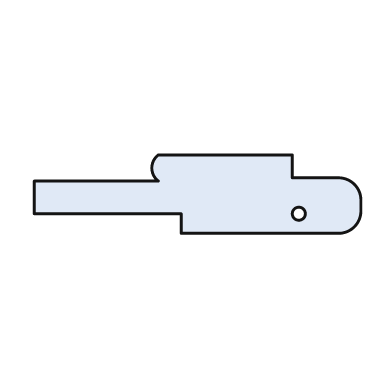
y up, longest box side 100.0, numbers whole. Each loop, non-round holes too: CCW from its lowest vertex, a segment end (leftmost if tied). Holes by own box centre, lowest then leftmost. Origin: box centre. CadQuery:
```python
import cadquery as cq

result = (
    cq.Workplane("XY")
    .moveTo(-5.0, -12.0)
    .lineTo(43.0, -12.0)
    .threePointArc((48.0, -10.0), (50.0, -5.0))
    .lineTo(50.0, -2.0)
    .threePointArc((48.0, 3.0), (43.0, 5.0))
    .lineTo(29.0, 5.0)
    .lineTo(29.0, 12.0)
    .lineTo(-12.0, 12.0)
    .threePointArc((-14.0, 8.0), (-12.0, 4.0))
    .lineTo(-50.0, 4.0)
    .lineTo(-50.0, -6.0)
    .lineTo(-5.0, -6.0)
    .close()
    .moveTo(31.0, -6.0)
    .circle(2.0)
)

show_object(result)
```